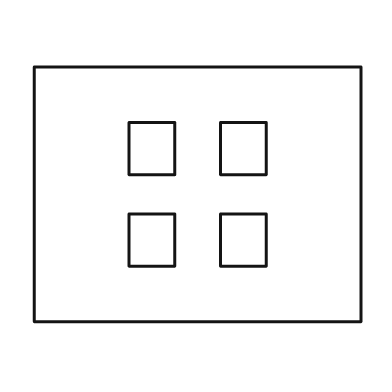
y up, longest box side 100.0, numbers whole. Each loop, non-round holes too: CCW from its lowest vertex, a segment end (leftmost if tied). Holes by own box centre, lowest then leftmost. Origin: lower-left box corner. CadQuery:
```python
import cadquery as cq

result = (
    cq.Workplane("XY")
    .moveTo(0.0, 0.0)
    .lineTo(100.0, 0.0)
    .lineTo(100.0, 78.0)
    .lineTo(0.0, 78.0)
    .close()
    .moveTo(29.0, 17.0)
    .lineTo(43.0, 17.0)
    .lineTo(43.0, 33.0)
    .lineTo(29.0, 33.0)
    .close()
    .moveTo(57.0, 17.0)
    .lineTo(71.0, 17.0)
    .lineTo(71.0, 33.0)
    .lineTo(57.0, 33.0)
    .close()
    .moveTo(29.0, 45.0)
    .lineTo(43.0, 45.0)
    .lineTo(43.0, 61.0)
    .lineTo(29.0, 61.0)
    .close()
    .moveTo(57.0, 45.0)
    .lineTo(71.0, 45.0)
    .lineTo(71.0, 61.0)
    .lineTo(57.0, 61.0)
    .close()
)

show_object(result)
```